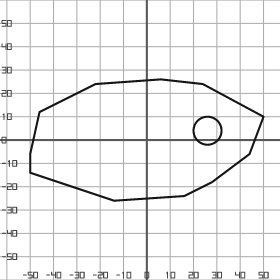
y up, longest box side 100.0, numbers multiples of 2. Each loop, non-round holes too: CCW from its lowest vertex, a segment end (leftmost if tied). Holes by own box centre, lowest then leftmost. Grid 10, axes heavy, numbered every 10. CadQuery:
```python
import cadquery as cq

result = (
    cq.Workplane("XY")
    .moveTo(-14.0, -26.0)
    .lineTo(16.0, -24.0)
    .lineTo(28.0, -18.0)
    .lineTo(44.0, -6.0)
    .lineTo(50.0, 10.0)
    .lineTo(24.0, 24.0)
    .lineTo(6.0, 26.0)
    .lineTo(-22.0, 24.0)
    .lineTo(-46.0, 12.0)
    .lineTo(-50.0, -6.0)
    .lineTo(-50.0, -14.0)
    .close()
    .moveTo(26.0, 4.0)
    .circle(6.0)
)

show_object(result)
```